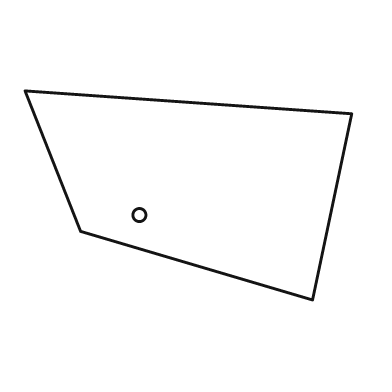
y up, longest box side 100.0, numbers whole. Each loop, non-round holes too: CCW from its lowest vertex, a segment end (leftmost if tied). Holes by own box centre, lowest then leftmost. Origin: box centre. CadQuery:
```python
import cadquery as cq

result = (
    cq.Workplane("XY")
    .moveTo(38.0, -32.0)
    .lineTo(50.0, 25.0)
    .lineTo(-50.0, 32.0)
    .lineTo(-33.0, -11.0)
    .close()
    .moveTo(-15.0, -6.0)
    .circle(2.0)
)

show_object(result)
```